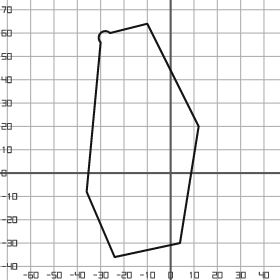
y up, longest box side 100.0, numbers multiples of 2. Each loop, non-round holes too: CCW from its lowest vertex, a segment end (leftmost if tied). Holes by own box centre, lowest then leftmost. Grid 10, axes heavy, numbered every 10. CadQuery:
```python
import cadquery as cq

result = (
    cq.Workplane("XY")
    .moveTo(-24.0, -36.0)
    .lineTo(4.0, -30.0)
    .lineTo(12.0, 20.0)
    .lineTo(-10.0, 64.0)
    .lineTo(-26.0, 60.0)
    .threePointArc((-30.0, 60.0), (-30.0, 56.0))
    .lineTo(-36.0, -8.0)
    .close()
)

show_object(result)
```